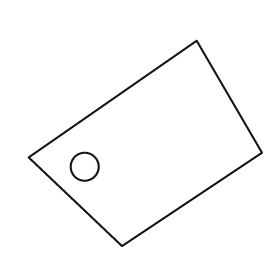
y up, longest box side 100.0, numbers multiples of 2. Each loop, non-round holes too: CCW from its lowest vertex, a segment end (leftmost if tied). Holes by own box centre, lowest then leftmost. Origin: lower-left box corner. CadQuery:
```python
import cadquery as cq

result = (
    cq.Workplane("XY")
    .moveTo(40.0, 0.0)
    .lineTo(100.0, 40.0)
    .lineTo(72.0, 88.0)
    .lineTo(0.0, 38.0)
    .close()
    .moveTo(24.0, 34.0)
    .circle(6.0)
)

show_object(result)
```